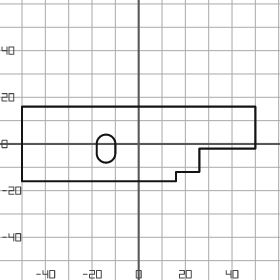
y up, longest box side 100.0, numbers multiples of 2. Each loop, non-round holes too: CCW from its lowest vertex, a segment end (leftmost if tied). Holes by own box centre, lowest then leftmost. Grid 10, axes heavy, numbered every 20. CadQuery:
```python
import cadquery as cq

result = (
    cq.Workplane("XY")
    .moveTo(-50.0, -16.0)
    .lineTo(16.0, -16.0)
    .lineTo(16.0, -12.0)
    .lineTo(26.0, -12.0)
    .lineTo(26.0, -2.0)
    .lineTo(50.0, -2.0)
    .lineTo(50.0, 16.0)
    .lineTo(-50.0, 16.0)
    .close()
    .moveTo(-18.0, -4.0)
    .threePointArc((-14.0, -8.0), (-10.0, -4.0))
    .lineTo(-10.0, 0.0)
    .threePointArc((-14.0, 4.0), (-18.0, 0.0))
    .close()
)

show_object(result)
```